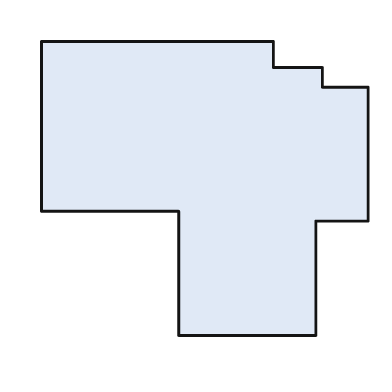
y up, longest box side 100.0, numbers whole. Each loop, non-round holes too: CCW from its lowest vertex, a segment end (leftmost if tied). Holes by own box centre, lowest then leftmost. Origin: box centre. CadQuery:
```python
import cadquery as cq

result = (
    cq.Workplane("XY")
    .moveTo(-8.0, -45.0)
    .lineTo(34.0, -45.0)
    .lineTo(34.0, -10.0)
    .lineTo(50.0, -10.0)
    .lineTo(50.0, 31.0)
    .lineTo(36.0, 31.0)
    .lineTo(36.0, 37.0)
    .lineTo(21.0, 37.0)
    .lineTo(21.0, 45.0)
    .lineTo(-50.0, 45.0)
    .lineTo(-50.0, -7.0)
    .lineTo(-8.0, -7.0)
    .close()
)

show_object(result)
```